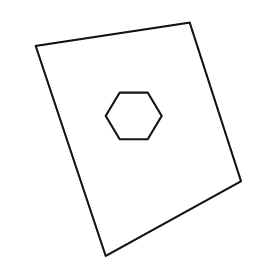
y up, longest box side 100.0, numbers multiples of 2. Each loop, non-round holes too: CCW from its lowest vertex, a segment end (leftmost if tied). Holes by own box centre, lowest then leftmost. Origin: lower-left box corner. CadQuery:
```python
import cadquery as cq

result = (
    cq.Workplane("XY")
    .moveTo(30.0, 0.0)
    .lineTo(88.0, 32.0)
    .lineTo(66.0, 100.0)
    .lineTo(0.0, 90.0)
    .close()
    .moveTo(36.0, 50.0)
    .lineTo(48.0, 50.0)
    .lineTo(54.0, 60.0)
    .lineTo(48.0, 70.0)
    .lineTo(36.0, 70.0)
    .lineTo(30.0, 60.0)
    .close()
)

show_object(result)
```